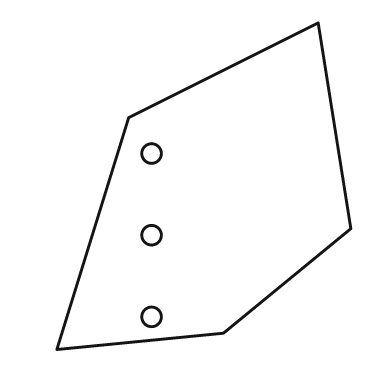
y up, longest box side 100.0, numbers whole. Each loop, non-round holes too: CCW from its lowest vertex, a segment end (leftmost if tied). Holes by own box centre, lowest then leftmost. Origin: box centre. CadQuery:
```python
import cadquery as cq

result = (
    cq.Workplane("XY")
    .moveTo(-45.0, -50.0)
    .lineTo(6.0, -45.0)
    .lineTo(45.0, -13.0)
    .lineTo(35.0, 50.0)
    .lineTo(-23.0, 21.0)
    .close()
    .moveTo(-16.0, -40.0)
    .circle(3.0)
    .moveTo(-16.0, -15.0)
    .circle(3.0)
    .moveTo(-16.0, 10.0)
    .circle(3.0)
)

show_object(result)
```